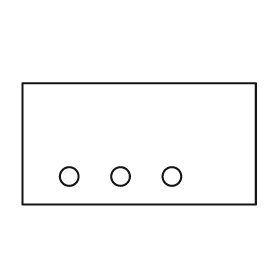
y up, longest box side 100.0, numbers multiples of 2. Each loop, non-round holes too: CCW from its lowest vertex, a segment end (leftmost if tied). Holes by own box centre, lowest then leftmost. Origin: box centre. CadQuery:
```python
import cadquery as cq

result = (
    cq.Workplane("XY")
    .moveTo(-50.0, -26.0)
    .lineTo(50.0, -26.0)
    .lineTo(50.0, 26.0)
    .lineTo(-50.0, 26.0)
    .close()
    .moveTo(-30.0, -14.0)
    .circle(4.0)
    .moveTo(-8.0, -14.0)
    .circle(4.0)
    .moveTo(14.0, -14.0)
    .circle(4.0)
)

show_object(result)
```